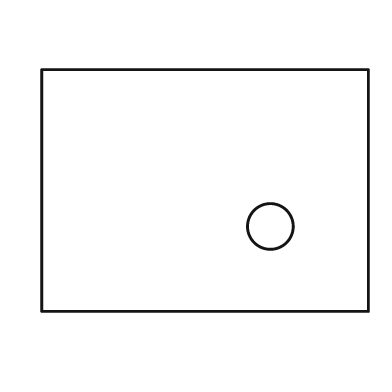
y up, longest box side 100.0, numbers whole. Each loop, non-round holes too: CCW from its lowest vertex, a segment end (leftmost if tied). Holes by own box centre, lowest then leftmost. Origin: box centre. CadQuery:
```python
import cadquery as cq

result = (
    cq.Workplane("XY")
    .moveTo(-50.0, -37.0)
    .lineTo(50.0, -37.0)
    .lineTo(50.0, 37.0)
    .lineTo(-50.0, 37.0)
    .close()
    .moveTo(20.0, -11.0)
    .circle(7.0)
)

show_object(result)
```